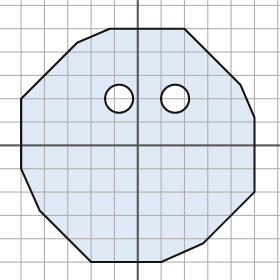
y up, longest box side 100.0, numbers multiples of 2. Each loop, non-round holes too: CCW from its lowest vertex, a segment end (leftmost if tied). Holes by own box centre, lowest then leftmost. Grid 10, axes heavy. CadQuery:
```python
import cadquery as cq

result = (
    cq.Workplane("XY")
    .moveTo(-20.0, -50.0)
    .lineTo(10.0, -50.0)
    .lineTo(28.0, -42.0)
    .lineTo(50.0, -20.0)
    .lineTo(50.0, 12.0)
    .lineTo(44.0, 26.0)
    .lineTo(20.0, 50.0)
    .lineTo(-12.0, 50.0)
    .lineTo(-26.0, 44.0)
    .lineTo(-50.0, 20.0)
    .lineTo(-50.0, -10.0)
    .lineTo(-42.0, -28.0)
    .close()
    .moveTo(-8.0, 20.0)
    .circle(6.0)
    .moveTo(16.0, 20.0)
    .circle(6.0)
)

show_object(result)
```